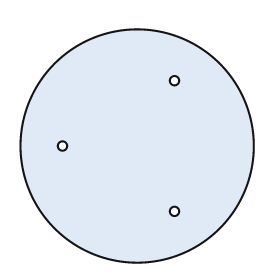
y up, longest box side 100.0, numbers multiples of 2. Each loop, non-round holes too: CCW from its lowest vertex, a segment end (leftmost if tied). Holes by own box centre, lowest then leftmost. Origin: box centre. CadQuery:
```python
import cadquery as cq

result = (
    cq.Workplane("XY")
    .moveTo(0.0, 0.0)
    .circle(50.0)
    .moveTo(16.0, -28.0)
    .circle(2.0)
    .moveTo(-32.0, 0.0)
    .circle(2.0)
    .moveTo(16.0, 28.0)
    .circle(2.0)
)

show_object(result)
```